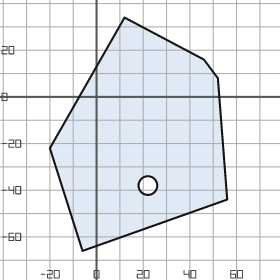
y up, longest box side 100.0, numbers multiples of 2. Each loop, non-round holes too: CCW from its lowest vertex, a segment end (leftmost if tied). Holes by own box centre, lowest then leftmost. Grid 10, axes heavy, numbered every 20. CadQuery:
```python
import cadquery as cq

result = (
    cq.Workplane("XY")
    .moveTo(-6.0, -66.0)
    .lineTo(56.0, -44.0)
    .lineTo(52.0, 8.0)
    .lineTo(46.0, 16.0)
    .lineTo(12.0, 34.0)
    .lineTo(-20.0, -22.0)
    .close()
    .moveTo(22.0, -38.0)
    .circle(4.0)
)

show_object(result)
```